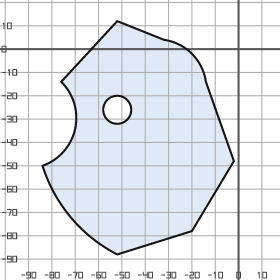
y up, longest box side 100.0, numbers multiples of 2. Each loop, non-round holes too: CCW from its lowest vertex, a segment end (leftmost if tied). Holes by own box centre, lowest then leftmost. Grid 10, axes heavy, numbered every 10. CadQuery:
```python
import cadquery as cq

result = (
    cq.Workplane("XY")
    .moveTo(-52.0, -88.0)
    .lineTo(-20.0, -78.0)
    .lineTo(-2.0, -48.0)
    .lineTo(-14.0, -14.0)
    .threePointArc((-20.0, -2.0), (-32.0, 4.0))
    .lineTo(-52.0, 12.0)
    .lineTo(-76.0, -14.0)
    .threePointArc((-70.0, -34.0), (-84.0, -50.0))
    .threePointArc((-72.0, -72.0), (-52.0, -88.0))
    .close()
    .moveTo(-52.0, -26.0)
    .circle(6.0)
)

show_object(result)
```